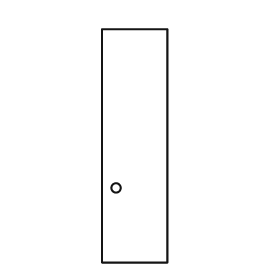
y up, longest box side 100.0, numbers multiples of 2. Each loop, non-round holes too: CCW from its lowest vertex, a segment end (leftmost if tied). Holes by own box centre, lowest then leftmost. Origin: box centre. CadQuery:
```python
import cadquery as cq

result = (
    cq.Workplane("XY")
    .moveTo(-14.0, -50.0)
    .lineTo(14.0, -50.0)
    .lineTo(14.0, 50.0)
    .lineTo(-14.0, 50.0)
    .close()
    .moveTo(-8.0, -18.0)
    .circle(2.0)
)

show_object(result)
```